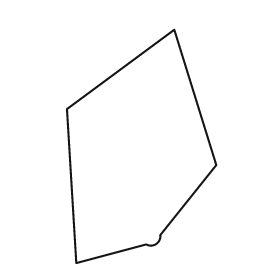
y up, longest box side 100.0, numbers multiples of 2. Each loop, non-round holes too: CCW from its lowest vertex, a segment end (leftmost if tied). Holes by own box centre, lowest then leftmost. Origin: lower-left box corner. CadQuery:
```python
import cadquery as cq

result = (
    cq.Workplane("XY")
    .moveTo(4.0, 0.0)
    .lineTo(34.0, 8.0)
    .threePointArc((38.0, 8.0), (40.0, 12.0))
    .lineTo(64.0, 42.0)
    .lineTo(46.0, 100.0)
    .lineTo(0.0, 66.0)
    .close()
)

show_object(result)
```